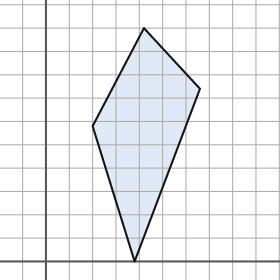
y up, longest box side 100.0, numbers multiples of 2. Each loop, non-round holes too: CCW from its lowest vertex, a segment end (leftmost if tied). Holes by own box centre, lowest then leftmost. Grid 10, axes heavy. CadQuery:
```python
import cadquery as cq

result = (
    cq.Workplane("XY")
    .moveTo(38.0, 0.0)
    .lineTo(66.0, 74.0)
    .lineTo(42.0, 100.0)
    .lineTo(20.0, 58.0)
    .close()
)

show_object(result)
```